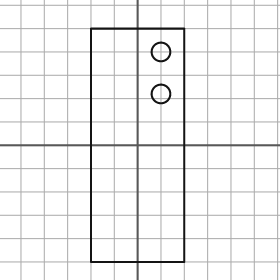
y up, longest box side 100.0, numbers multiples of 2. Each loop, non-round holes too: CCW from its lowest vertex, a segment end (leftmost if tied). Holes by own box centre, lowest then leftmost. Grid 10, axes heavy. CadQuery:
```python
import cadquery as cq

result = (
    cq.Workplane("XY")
    .moveTo(-20.0, -50.0)
    .lineTo(20.0, -50.0)
    .lineTo(20.0, 50.0)
    .lineTo(-20.0, 50.0)
    .close()
    .moveTo(10.0, 22.0)
    .circle(4.0)
    .moveTo(10.0, 40.0)
    .circle(4.0)
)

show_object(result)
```